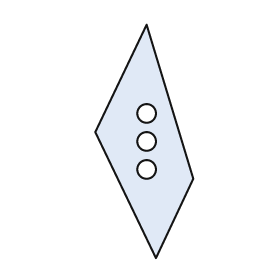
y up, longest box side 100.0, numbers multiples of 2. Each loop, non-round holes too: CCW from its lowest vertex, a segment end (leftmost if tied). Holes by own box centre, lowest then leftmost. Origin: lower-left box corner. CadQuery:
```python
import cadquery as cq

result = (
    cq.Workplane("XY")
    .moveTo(26.0, 0.0)
    .lineTo(42.0, 34.0)
    .lineTo(22.0, 100.0)
    .lineTo(0.0, 54.0)
    .close()
    .moveTo(22.0, 38.0)
    .circle(4.0)
    .moveTo(22.0, 50.0)
    .circle(4.0)
    .moveTo(22.0, 62.0)
    .circle(4.0)
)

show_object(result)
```